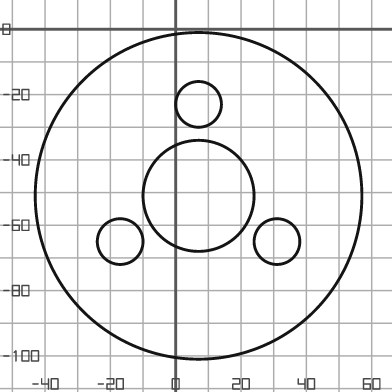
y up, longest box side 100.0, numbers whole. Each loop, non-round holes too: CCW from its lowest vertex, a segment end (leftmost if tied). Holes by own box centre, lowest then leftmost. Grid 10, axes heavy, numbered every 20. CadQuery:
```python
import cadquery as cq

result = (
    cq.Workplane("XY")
    .moveTo(7.0, -51.0)
    .circle(50.0)
    .moveTo(-17.0, -65.0)
    .circle(7.0)
    .moveTo(31.0, -65.0)
    .circle(7.0)
    .moveTo(7.0, -51.0)
    .circle(17.0)
    .moveTo(7.0, -23.0)
    .circle(7.0)
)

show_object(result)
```